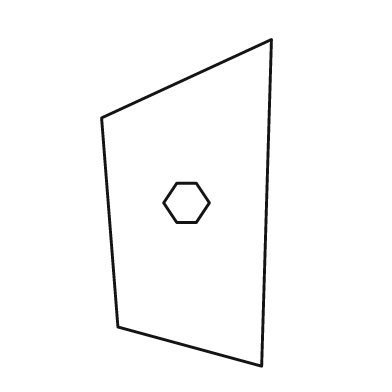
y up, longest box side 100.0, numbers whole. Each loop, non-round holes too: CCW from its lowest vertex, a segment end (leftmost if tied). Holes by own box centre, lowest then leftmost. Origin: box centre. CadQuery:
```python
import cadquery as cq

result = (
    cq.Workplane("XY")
    .moveTo(23.0, -50.0)
    .lineTo(26.0, 50.0)
    .lineTo(-26.0, 26.0)
    .lineTo(-21.0, -38.0)
    .close()
    .moveTo(-3.0, -6.0)
    .lineTo(3.0, -6.0)
    .lineTo(7.0, 0.0)
    .lineTo(3.0, 6.0)
    .lineTo(-3.0, 6.0)
    .lineTo(-7.0, 0.0)
    .close()
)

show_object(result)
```